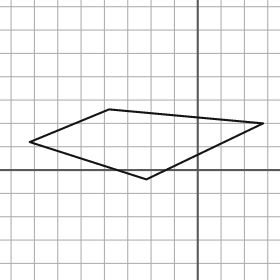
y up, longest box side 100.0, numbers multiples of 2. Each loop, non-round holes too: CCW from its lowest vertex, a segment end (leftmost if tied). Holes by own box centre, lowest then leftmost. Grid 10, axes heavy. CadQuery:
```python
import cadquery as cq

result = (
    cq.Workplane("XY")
    .moveTo(-22.0, -4.0)
    .lineTo(28.0, 20.0)
    .lineTo(-38.0, 26.0)
    .lineTo(-72.0, 12.0)
    .close()
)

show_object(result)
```